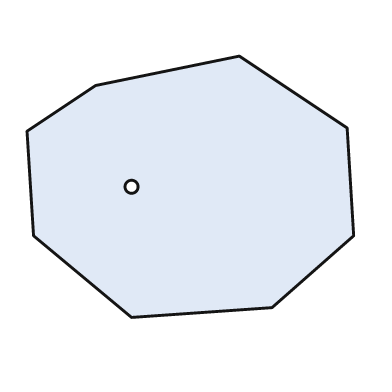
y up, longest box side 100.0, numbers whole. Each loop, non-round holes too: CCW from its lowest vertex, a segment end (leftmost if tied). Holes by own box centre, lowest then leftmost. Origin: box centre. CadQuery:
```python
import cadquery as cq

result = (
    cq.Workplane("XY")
    .moveTo(-18.0, -40.0)
    .lineTo(25.0, -37.0)
    .lineTo(50.0, -15.0)
    .lineTo(48.0, 18.0)
    .lineTo(15.0, 40.0)
    .lineTo(-29.0, 31.0)
    .lineTo(-50.0, 17.0)
    .lineTo(-48.0, -15.0)
    .close()
    .moveTo(-18.0, 0.0)
    .circle(2.0)
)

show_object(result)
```